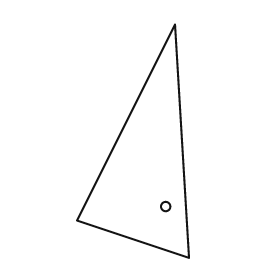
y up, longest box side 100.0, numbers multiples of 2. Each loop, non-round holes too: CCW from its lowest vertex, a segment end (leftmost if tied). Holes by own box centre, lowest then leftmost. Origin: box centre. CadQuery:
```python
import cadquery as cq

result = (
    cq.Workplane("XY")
    .moveTo(24.0, -50.0)
    .lineTo(18.0, 50.0)
    .lineTo(-24.0, -34.0)
    .close()
    .moveTo(14.0, -28.0)
    .circle(2.0)
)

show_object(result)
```